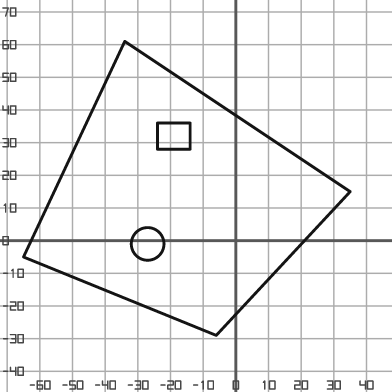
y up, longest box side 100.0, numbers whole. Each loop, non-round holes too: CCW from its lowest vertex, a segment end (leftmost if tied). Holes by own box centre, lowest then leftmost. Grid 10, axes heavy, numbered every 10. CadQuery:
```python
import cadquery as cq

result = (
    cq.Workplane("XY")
    .moveTo(-6.0, -29.0)
    .lineTo(35.0, 15.0)
    .lineTo(-34.0, 61.0)
    .lineTo(-65.0, -5.0)
    .close()
    .moveTo(-27.0, -1.0)
    .circle(5.0)
    .moveTo(-24.0, 28.0)
    .lineTo(-14.0, 28.0)
    .lineTo(-14.0, 36.0)
    .lineTo(-24.0, 36.0)
    .close()
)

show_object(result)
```